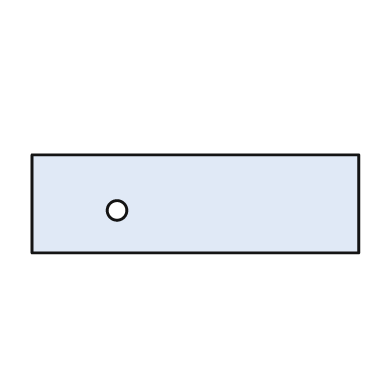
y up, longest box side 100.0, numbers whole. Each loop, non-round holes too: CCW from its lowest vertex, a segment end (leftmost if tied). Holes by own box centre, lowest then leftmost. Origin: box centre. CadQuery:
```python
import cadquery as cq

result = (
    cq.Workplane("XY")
    .moveTo(-50.0, -15.0)
    .lineTo(50.0, -15.0)
    .lineTo(50.0, 15.0)
    .lineTo(-50.0, 15.0)
    .close()
    .moveTo(-24.0, -2.0)
    .circle(3.0)
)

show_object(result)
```